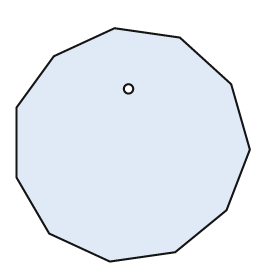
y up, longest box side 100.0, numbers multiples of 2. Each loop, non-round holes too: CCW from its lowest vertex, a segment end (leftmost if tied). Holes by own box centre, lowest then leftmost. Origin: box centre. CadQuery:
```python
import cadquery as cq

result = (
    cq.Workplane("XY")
    .moveTo(-10.0, -50.0)
    .lineTo(18.0, -46.0)
    .lineTo(40.0, -28.0)
    .lineTo(50.0, -2.0)
    .lineTo(42.0, 26.0)
    .lineTo(20.0, 46.0)
    .lineTo(-8.0, 50.0)
    .lineTo(-34.0, 38.0)
    .lineTo(-50.0, 16.0)
    .lineTo(-50.0, -14.0)
    .lineTo(-36.0, -38.0)
    .close()
    .moveTo(-2.0, 24.0)
    .circle(2.0)
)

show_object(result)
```